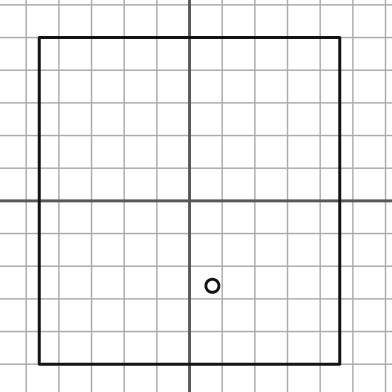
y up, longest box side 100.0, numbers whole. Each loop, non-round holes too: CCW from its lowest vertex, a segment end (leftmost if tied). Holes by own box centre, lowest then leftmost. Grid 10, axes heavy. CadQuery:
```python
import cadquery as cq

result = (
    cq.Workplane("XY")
    .moveTo(-46.0, -50.0)
    .lineTo(46.0, -50.0)
    .lineTo(46.0, 50.0)
    .lineTo(-46.0, 50.0)
    .close()
    .moveTo(7.0, -26.0)
    .circle(2.0)
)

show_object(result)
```